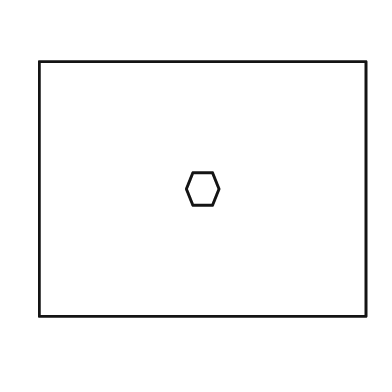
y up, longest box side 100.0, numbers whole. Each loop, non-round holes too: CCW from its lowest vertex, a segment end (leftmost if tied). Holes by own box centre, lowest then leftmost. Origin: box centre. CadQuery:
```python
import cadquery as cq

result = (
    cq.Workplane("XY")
    .moveTo(-50.0, -39.0)
    .lineTo(50.0, -39.0)
    .lineTo(50.0, 39.0)
    .lineTo(-50.0, 39.0)
    .close()
    .moveTo(-3.0, -5.0)
    .lineTo(3.0, -5.0)
    .lineTo(5.0, 0.0)
    .lineTo(3.0, 5.0)
    .lineTo(-3.0, 5.0)
    .lineTo(-5.0, 0.0)
    .close()
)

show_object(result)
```